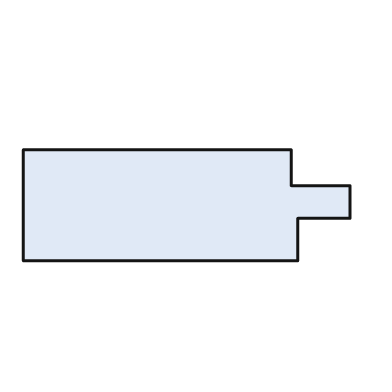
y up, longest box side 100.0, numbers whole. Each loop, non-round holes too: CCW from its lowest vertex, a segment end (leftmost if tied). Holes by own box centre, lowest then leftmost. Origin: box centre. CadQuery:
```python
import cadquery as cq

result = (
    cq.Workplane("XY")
    .moveTo(-50.0, -17.0)
    .lineTo(34.0, -17.0)
    .lineTo(34.0, -4.0)
    .lineTo(50.0, -4.0)
    .lineTo(50.0, 6.0)
    .lineTo(32.0, 6.0)
    .lineTo(32.0, 17.0)
    .lineTo(-50.0, 17.0)
    .close()
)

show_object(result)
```